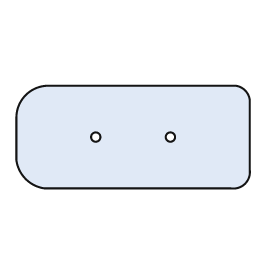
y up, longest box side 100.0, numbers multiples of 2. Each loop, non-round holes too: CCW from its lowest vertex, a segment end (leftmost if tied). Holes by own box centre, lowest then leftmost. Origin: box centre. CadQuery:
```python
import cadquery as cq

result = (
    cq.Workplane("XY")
    .moveTo(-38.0, -22.0)
    .lineTo(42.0, -22.0)
    .threePointArc((48.0, -20.0), (50.0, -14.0))
    .lineTo(50.0, 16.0)
    .threePointArc((48.0, 20.0), (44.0, 22.0))
    .lineTo(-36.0, 22.0)
    .threePointArc((-46.0, 18.0), (-50.0, 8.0))
    .lineTo(-50.0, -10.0)
    .threePointArc((-46.0, -18.0), (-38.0, -22.0))
    .close()
    .moveTo(-16.0, 0.0)
    .circle(2.0)
    .moveTo(16.0, 0.0)
    .circle(2.0)
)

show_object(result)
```